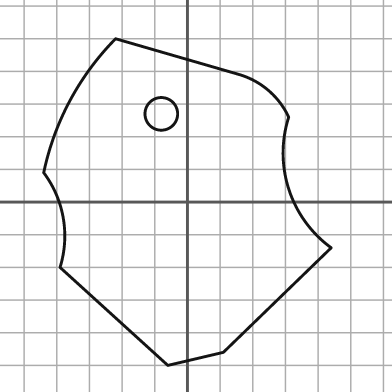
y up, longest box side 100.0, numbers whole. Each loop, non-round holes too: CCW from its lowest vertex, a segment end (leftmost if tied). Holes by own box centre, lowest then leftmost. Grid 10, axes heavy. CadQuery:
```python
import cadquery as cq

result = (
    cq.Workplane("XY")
    .moveTo(-6.0, -50.0)
    .lineTo(11.0, -46.0)
    .lineTo(44.0, -14.0)
    .threePointArc((31.0, 4.0), (31.0, 26.0))
    .threePointArc((25.0, 34.0), (16.0, 39.0))
    .lineTo(-22.0, 50.0)
    .threePointArc((-36.0, 31.0), (-44.0, 9.0))
    .threePointArc((-38.0, -5.0), (-39.0, -20.0))
    .close()
    .moveTo(-8.0, 27.0)
    .circle(5.0)
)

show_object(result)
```